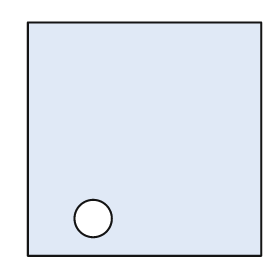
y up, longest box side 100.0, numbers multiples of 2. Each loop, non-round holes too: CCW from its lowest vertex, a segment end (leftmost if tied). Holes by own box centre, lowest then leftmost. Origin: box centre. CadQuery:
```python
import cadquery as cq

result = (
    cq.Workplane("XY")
    .moveTo(-50.0, -50.0)
    .lineTo(50.0, -50.0)
    .lineTo(50.0, 50.0)
    .lineTo(-50.0, 50.0)
    .close()
    .moveTo(-22.0, -34.0)
    .circle(8.0)
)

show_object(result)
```